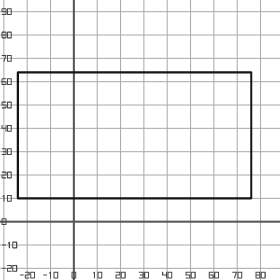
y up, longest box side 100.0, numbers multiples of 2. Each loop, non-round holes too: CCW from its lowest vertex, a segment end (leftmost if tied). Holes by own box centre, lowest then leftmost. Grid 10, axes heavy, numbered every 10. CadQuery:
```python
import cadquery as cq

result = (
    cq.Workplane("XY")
    .moveTo(-24.0, 10.0)
    .lineTo(76.0, 10.0)
    .lineTo(76.0, 64.0)
    .lineTo(-24.0, 64.0)
    .close()
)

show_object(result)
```